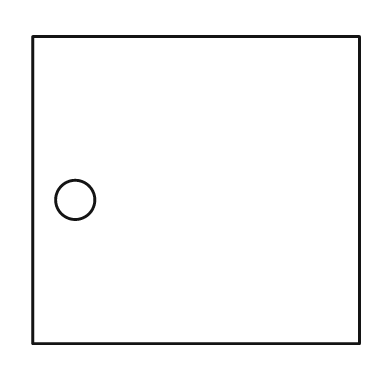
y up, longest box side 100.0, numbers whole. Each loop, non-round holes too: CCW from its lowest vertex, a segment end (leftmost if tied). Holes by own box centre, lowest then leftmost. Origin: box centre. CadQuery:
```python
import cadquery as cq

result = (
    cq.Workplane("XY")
    .moveTo(-50.0, -47.0)
    .lineTo(50.0, -47.0)
    .lineTo(50.0, 47.0)
    .lineTo(-50.0, 47.0)
    .close()
    .moveTo(-37.0, -3.0)
    .circle(6.0)
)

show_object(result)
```